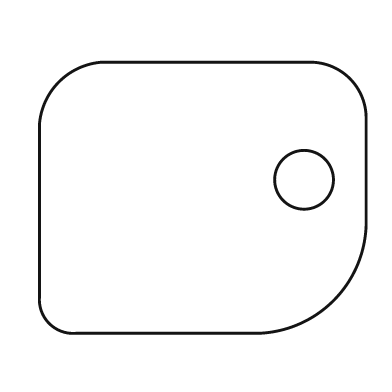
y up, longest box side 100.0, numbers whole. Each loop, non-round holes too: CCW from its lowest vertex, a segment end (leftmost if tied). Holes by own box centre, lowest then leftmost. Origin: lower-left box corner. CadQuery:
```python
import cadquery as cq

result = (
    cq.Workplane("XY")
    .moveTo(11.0, 0.0)
    .lineTo(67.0, 0.0)
    .threePointArc((90.0, 10.0), (100.0, 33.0))
    .lineTo(100.0, 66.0)
    .threePointArc((95.0, 78.0), (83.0, 83.0))
    .lineTo(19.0, 83.0)
    .threePointArc((6.0, 77.0), (0.0, 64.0))
    .lineTo(0.0, 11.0)
    .threePointArc((3.0, 3.0), (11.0, 0.0))
    .close()
    .moveTo(81.0, 47.0)
    .circle(9.0)
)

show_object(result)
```